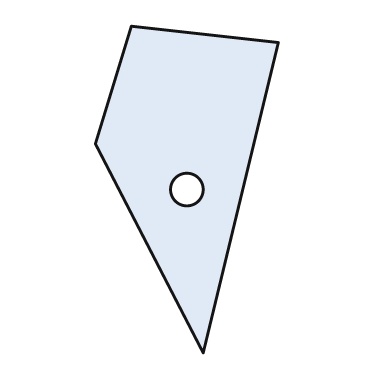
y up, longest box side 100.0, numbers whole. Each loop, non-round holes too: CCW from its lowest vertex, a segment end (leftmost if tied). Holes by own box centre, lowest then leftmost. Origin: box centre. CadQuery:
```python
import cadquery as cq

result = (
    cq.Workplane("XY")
    .moveTo(5.0, -50.0)
    .lineTo(28.0, 45.0)
    .lineTo(-17.0, 50.0)
    .lineTo(-28.0, 14.0)
    .close()
    .moveTo(0.0, 0.0)
    .circle(5.0)
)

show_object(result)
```